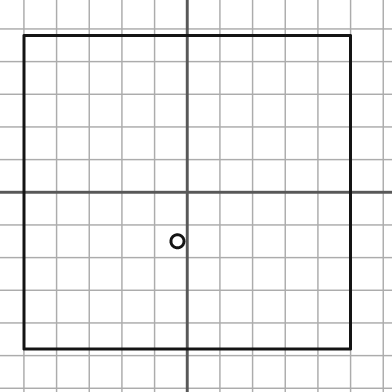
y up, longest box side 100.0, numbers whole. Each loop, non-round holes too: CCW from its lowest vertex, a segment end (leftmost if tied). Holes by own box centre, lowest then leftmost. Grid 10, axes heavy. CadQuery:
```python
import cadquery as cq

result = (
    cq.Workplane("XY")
    .moveTo(-50.0, -48.0)
    .lineTo(50.0, -48.0)
    .lineTo(50.0, 48.0)
    .lineTo(-50.0, 48.0)
    .close()
    .moveTo(-3.0, -15.0)
    .circle(2.0)
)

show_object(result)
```